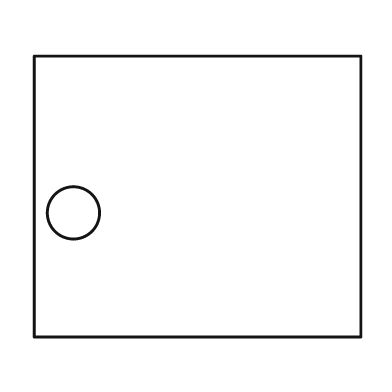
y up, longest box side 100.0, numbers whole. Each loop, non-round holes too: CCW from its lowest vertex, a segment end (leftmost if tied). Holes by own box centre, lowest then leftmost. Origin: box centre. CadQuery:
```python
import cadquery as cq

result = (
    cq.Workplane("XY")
    .moveTo(-50.0, -43.0)
    .lineTo(50.0, -43.0)
    .lineTo(50.0, 43.0)
    .lineTo(-50.0, 43.0)
    .close()
    .moveTo(-38.0, -5.0)
    .circle(8.0)
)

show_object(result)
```